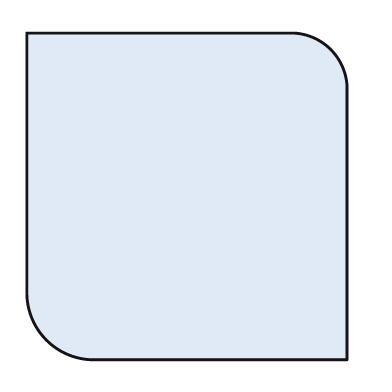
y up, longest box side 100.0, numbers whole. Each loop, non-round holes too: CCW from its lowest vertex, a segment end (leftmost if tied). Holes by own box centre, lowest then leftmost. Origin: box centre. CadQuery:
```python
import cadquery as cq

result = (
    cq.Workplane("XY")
    .moveTo(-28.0, -50.0)
    .lineTo(49.0, -50.0)
    .lineTo(49.0, 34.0)
    .threePointArc((44.0, 45.0), (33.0, 50.0))
    .lineTo(-49.0, 50.0)
    .lineTo(-49.0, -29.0)
    .threePointArc((-43.0, -44.0), (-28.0, -50.0))
    .close()
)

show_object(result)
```